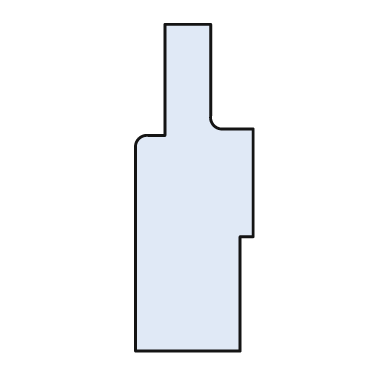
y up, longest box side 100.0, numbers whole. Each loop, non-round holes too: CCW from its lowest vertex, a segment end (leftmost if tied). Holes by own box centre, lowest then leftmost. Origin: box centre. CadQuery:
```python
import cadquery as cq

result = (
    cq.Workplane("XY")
    .moveTo(-18.0, -50.0)
    .lineTo(14.0, -50.0)
    .lineTo(14.0, -15.0)
    .lineTo(18.0, -15.0)
    .lineTo(18.0, 18.0)
    .lineTo(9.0, 18.0)
    .threePointArc((6.0, 19.0), (5.0, 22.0))
    .lineTo(5.0, 50.0)
    .lineTo(-9.0, 50.0)
    .lineTo(-9.0, 16.0)
    .lineTo(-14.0, 16.0)
    .threePointArc((-17.0, 15.0), (-18.0, 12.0))
    .close()
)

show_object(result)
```